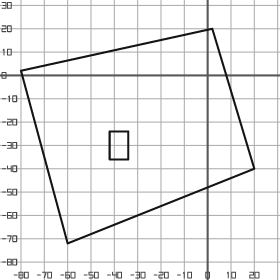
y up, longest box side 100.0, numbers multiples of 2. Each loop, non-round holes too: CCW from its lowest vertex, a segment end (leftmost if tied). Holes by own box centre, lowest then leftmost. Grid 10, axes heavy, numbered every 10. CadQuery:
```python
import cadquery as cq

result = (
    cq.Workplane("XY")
    .moveTo(-60.0, -72.0)
    .lineTo(20.0, -40.0)
    .lineTo(2.0, 20.0)
    .lineTo(-80.0, 2.0)
    .close()
    .moveTo(-42.0, -36.0)
    .lineTo(-34.0, -36.0)
    .lineTo(-34.0, -24.0)
    .lineTo(-42.0, -24.0)
    .close()
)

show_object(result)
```